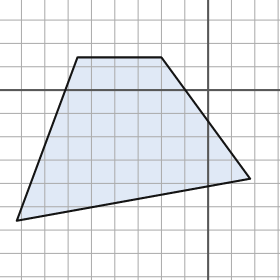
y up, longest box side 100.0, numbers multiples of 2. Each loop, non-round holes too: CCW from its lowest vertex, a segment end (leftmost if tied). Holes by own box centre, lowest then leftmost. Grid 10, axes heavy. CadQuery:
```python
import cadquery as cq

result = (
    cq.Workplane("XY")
    .moveTo(-82.0, -56.0)
    .lineTo(18.0, -38.0)
    .lineTo(-20.0, 14.0)
    .lineTo(-56.0, 14.0)
    .close()
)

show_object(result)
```